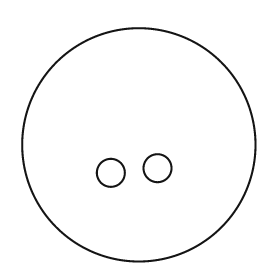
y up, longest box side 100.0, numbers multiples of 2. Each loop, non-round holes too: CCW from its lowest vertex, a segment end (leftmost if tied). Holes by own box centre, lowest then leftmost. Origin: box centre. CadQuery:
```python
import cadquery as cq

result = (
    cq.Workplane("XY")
    .moveTo(0.0, 0.0)
    .circle(50.0)
    .moveTo(-12.0, -12.0)
    .circle(6.0)
    .moveTo(8.0, -10.0)
    .circle(6.0)
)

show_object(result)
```